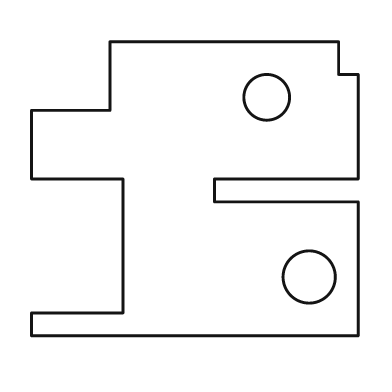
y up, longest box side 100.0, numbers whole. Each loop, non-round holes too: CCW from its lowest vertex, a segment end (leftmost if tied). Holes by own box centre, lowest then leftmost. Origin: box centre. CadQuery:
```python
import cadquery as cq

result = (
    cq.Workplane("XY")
    .moveTo(-50.0, -45.0)
    .lineTo(50.0, -45.0)
    .lineTo(50.0, -4.0)
    .lineTo(6.0, -4.0)
    .lineTo(6.0, 3.0)
    .lineTo(50.0, 3.0)
    .lineTo(50.0, 35.0)
    .lineTo(44.0, 35.0)
    .lineTo(44.0, 45.0)
    .lineTo(-26.0, 45.0)
    .lineTo(-26.0, 24.0)
    .lineTo(-50.0, 24.0)
    .lineTo(-50.0, 3.0)
    .lineTo(-22.0, 3.0)
    .lineTo(-22.0, -38.0)
    .lineTo(-50.0, -38.0)
    .close()
    .moveTo(35.0, -27.0)
    .circle(8.0)
    .moveTo(22.0, 28.0)
    .circle(7.0)
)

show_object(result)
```